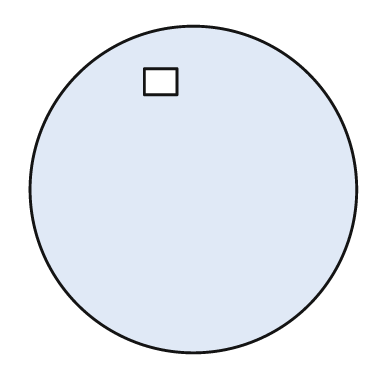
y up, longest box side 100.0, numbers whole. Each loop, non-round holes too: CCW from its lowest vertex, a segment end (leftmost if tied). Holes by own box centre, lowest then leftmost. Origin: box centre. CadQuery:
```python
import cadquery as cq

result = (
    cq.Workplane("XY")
    .moveTo(0.0, 0.0)
    .circle(50.0)
    .moveTo(-15.0, 29.0)
    .lineTo(-5.0, 29.0)
    .lineTo(-5.0, 37.0)
    .lineTo(-15.0, 37.0)
    .close()
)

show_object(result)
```